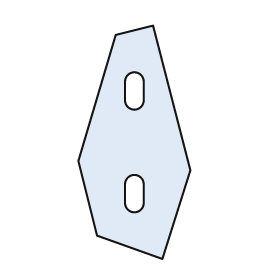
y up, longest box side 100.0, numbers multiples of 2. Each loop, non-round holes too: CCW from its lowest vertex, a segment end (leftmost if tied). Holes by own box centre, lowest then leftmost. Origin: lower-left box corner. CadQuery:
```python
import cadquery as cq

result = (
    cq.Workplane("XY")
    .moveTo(36.0, 0.0)
    .lineTo(48.0, 38.0)
    .lineTo(32.0, 100.0)
    .lineTo(16.0, 96.0)
    .lineTo(0.0, 42.0)
    .lineTo(8.0, 10.0)
    .close()
    .moveTo(20.0, 24.0)
    .threePointArc((24.0, 20.0), (28.0, 24.0))
    .lineTo(28.0, 32.0)
    .threePointArc((24.0, 36.0), (20.0, 32.0))
    .close()
    .moveTo(20.0, 68.0)
    .threePointArc((24.0, 64.0), (28.0, 68.0))
    .lineTo(28.0, 76.0)
    .threePointArc((24.0, 80.0), (20.0, 76.0))
    .close()
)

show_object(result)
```